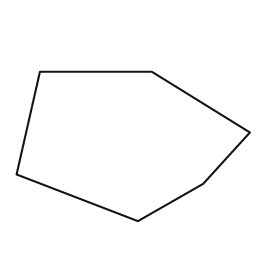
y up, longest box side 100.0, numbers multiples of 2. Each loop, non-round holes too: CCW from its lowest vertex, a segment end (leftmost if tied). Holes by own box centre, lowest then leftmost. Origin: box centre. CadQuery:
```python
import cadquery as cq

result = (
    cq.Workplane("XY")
    .moveTo(2.0, -32.0)
    .lineTo(30.0, -16.0)
    .lineTo(50.0, 6.0)
    .lineTo(8.0, 32.0)
    .lineTo(-40.0, 32.0)
    .lineTo(-50.0, -12.0)
    .close()
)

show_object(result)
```